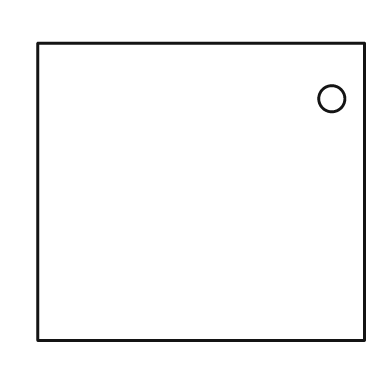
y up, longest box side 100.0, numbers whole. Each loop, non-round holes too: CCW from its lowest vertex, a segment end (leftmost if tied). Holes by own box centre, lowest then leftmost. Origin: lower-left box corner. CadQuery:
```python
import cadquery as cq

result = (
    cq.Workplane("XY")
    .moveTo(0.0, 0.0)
    .lineTo(100.0, 0.0)
    .lineTo(100.0, 91.0)
    .lineTo(0.0, 91.0)
    .close()
    .moveTo(90.0, 74.0)
    .circle(4.0)
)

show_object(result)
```